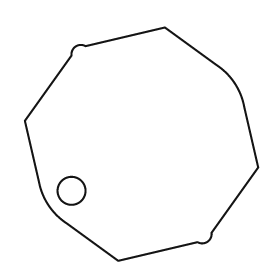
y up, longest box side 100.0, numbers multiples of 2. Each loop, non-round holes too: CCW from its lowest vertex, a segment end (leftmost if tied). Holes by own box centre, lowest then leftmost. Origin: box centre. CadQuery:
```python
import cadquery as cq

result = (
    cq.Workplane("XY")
    .moveTo(-10.0, -50.0)
    .lineTo(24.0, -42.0)
    .threePointArc((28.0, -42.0), (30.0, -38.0))
    .lineTo(50.0, -10.0)
    .lineTo(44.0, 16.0)
    .threePointArc((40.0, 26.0), (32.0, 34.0))
    .lineTo(10.0, 50.0)
    .lineTo(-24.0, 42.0)
    .threePointArc((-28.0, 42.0), (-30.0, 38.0))
    .lineTo(-50.0, 10.0)
    .lineTo(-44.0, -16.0)
    .threePointArc((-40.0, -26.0), (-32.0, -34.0))
    .close()
    .moveTo(-30.0, -20.0)
    .circle(6.0)
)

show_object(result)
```